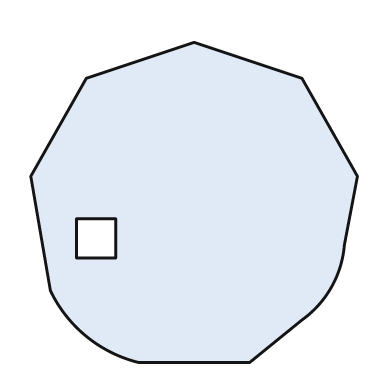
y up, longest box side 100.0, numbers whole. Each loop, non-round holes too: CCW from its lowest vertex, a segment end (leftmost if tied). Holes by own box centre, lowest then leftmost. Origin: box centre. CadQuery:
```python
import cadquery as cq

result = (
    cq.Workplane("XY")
    .moveTo(-17.0, -49.0)
    .lineTo(17.0, -49.0)
    .lineTo(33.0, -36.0)
    .threePointArc((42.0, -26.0), (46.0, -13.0))
    .lineTo(50.0, 8.0)
    .lineTo(33.0, 38.0)
    .lineTo(0.0, 49.0)
    .lineTo(-33.0, 38.0)
    .lineTo(-50.0, 8.0)
    .lineTo(-44.0, -27.0)
    .threePointArc((-33.0, -41.0), (-17.0, -49.0))
    .close()
    .moveTo(-36.0, -17.0)
    .lineTo(-24.0, -17.0)
    .lineTo(-24.0, -5.0)
    .lineTo(-36.0, -5.0)
    .close()
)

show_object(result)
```